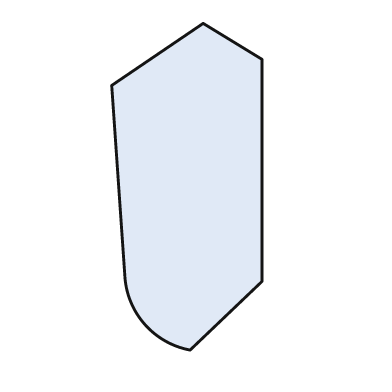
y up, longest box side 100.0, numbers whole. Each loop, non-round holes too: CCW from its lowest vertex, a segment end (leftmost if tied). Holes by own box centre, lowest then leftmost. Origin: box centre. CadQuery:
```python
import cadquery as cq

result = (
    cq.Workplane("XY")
    .moveTo(1.0, -50.0)
    .lineTo(23.0, -29.0)
    .lineTo(23.0, 39.0)
    .lineTo(5.0, 50.0)
    .lineTo(-23.0, 31.0)
    .lineTo(-19.0, -27.0)
    .threePointArc((-13.0, -42.0), (1.0, -50.0))
    .close()
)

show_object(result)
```